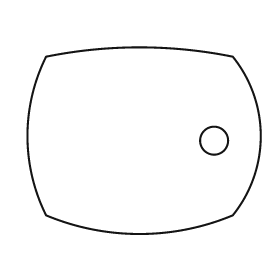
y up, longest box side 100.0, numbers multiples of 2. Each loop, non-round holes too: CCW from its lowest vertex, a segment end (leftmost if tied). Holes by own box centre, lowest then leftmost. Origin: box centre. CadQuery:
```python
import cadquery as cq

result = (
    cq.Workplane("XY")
    .moveTo(-42.0, -32.0)
    .threePointArc((-2.0, -40.0), (38.0, -32.0))
    .threePointArc((50.0, 2.0), (38.0, 36.0))
    .threePointArc((-2.0, 40.0), (-42.0, 36.0))
    .threePointArc((-50.0, 2.0), (-42.0, -32.0))
    .close()
    .moveTo(30.0, 0.0)
    .circle(6.0)
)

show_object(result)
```